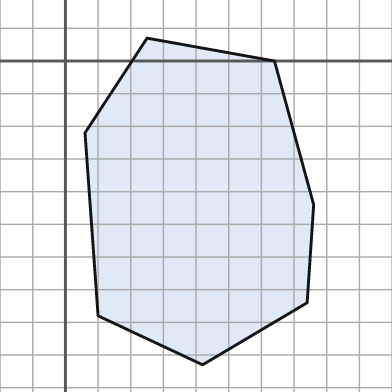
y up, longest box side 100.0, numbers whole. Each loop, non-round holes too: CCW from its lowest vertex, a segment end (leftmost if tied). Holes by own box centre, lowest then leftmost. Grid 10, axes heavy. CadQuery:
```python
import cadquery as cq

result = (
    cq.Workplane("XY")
    .moveTo(42.0, -93.0)
    .lineTo(74.0, -74.0)
    .lineTo(76.0, -44.0)
    .lineTo(64.0, 0.0)
    .lineTo(25.0, 7.0)
    .lineTo(6.0, -22.0)
    .lineTo(10.0, -78.0)
    .close()
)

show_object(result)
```